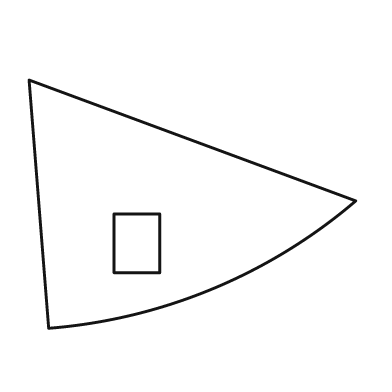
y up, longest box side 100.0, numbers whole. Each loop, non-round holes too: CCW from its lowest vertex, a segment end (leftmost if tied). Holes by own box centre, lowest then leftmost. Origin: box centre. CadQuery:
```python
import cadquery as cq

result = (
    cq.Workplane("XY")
    .moveTo(-44.0, -38.0)
    .threePointArc((6.0, -26.0), (50.0, 1.0))
    .lineTo(-50.0, 38.0)
    .close()
    .moveTo(-24.0, -21.0)
    .lineTo(-10.0, -21.0)
    .lineTo(-10.0, -3.0)
    .lineTo(-24.0, -3.0)
    .close()
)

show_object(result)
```